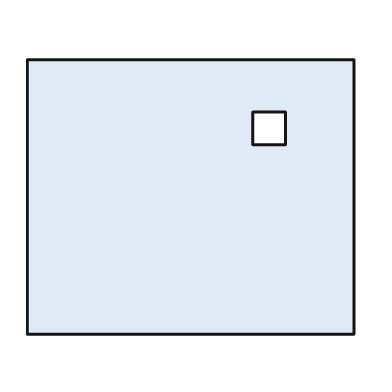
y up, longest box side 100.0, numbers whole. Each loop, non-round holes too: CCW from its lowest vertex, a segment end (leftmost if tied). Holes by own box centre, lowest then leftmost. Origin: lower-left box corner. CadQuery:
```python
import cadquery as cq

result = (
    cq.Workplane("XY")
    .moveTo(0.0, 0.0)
    .lineTo(100.0, 0.0)
    .lineTo(100.0, 84.0)
    .lineTo(0.0, 84.0)
    .close()
    .moveTo(69.0, 58.0)
    .lineTo(79.0, 58.0)
    .lineTo(79.0, 68.0)
    .lineTo(69.0, 68.0)
    .close()
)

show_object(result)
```